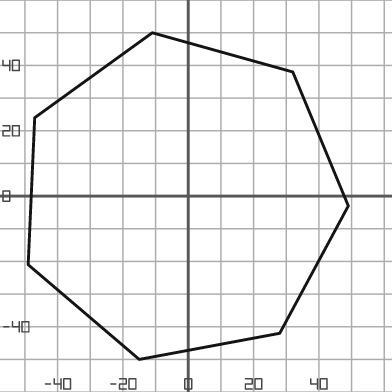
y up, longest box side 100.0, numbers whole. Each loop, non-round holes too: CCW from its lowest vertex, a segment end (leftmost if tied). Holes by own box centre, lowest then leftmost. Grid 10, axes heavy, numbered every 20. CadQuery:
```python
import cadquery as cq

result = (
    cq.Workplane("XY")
    .moveTo(-15.0, -50.0)
    .lineTo(28.0, -42.0)
    .lineTo(49.0, -3.0)
    .lineTo(32.0, 38.0)
    .lineTo(-11.0, 50.0)
    .lineTo(-47.0, 24.0)
    .lineTo(-49.0, -21.0)
    .close()
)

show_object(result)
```